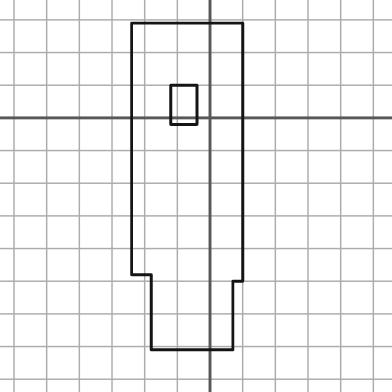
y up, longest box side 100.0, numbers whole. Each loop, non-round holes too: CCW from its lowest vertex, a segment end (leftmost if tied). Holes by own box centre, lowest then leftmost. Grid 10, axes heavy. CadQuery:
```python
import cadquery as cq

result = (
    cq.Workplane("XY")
    .moveTo(-18.0, -71.0)
    .lineTo(7.0, -71.0)
    .lineTo(7.0, -50.0)
    .lineTo(10.0, -50.0)
    .lineTo(10.0, 29.0)
    .lineTo(-24.0, 29.0)
    .lineTo(-24.0, -48.0)
    .lineTo(-18.0, -48.0)
    .close()
    .moveTo(-12.0, -2.0)
    .lineTo(-4.0, -2.0)
    .lineTo(-4.0, 10.0)
    .lineTo(-12.0, 10.0)
    .close()
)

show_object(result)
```